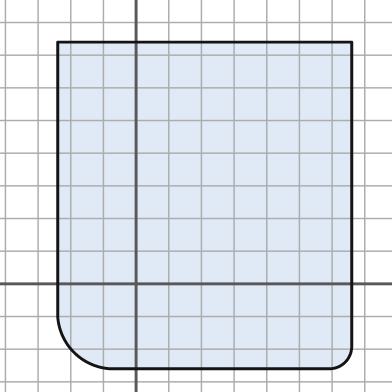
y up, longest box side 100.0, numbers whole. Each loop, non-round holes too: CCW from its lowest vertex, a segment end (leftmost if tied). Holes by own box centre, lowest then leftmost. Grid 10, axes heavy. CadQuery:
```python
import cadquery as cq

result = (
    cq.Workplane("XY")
    .moveTo(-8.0, -26.0)
    .lineTo(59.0, -26.0)
    .threePointArc((64.0, -24.0), (66.0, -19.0))
    .lineTo(66.0, 74.0)
    .lineTo(-24.0, 74.0)
    .lineTo(-24.0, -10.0)
    .threePointArc((-19.0, -21.0), (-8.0, -26.0))
    .close()
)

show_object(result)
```